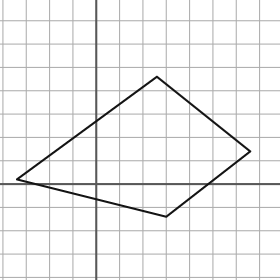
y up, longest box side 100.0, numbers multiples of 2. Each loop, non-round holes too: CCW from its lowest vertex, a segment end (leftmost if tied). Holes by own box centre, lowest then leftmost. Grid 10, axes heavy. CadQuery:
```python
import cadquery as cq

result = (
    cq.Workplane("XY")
    .moveTo(30.0, -14.0)
    .lineTo(66.0, 14.0)
    .lineTo(26.0, 46.0)
    .lineTo(-34.0, 2.0)
    .close()
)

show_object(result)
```